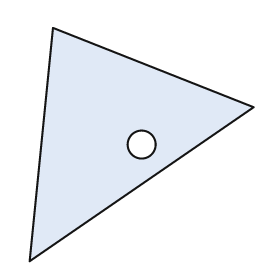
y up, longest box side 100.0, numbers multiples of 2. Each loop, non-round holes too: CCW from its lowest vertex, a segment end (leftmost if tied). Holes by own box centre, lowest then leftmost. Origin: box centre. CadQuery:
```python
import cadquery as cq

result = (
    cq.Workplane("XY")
    .moveTo(-48.0, -50.0)
    .lineTo(48.0, 16.0)
    .lineTo(-38.0, 50.0)
    .close()
    .moveTo(0.0, 0.0)
    .circle(6.0)
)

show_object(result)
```